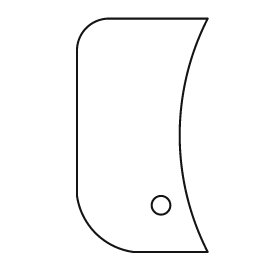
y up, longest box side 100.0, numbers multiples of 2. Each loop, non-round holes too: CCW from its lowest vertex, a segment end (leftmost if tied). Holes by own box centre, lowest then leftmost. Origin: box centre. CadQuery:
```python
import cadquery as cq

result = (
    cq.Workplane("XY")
    .moveTo(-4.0, -50.0)
    .lineTo(28.0, -50.0)
    .threePointArc((16.0, 0.0), (28.0, 50.0))
    .lineTo(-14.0, 50.0)
    .threePointArc((-24.0, 46.0), (-28.0, 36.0))
    .lineTo(-28.0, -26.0)
    .threePointArc((-20.0, -42.0), (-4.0, -50.0))
    .close()
    .moveTo(8.0, -30.0)
    .circle(4.0)
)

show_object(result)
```